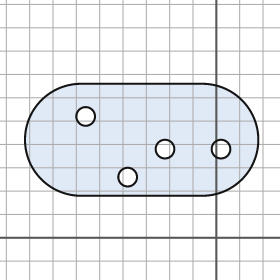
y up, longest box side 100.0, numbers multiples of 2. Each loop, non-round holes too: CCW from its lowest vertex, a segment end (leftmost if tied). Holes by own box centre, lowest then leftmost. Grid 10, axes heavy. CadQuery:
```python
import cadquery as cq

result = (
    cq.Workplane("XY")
    .moveTo(-58.0, 18.0)
    .lineTo(-6.0, 18.0)
    .threePointArc((18.0, 42.0), (-6.0, 66.0))
    .lineTo(-58.0, 66.0)
    .threePointArc((-82.0, 42.0), (-58.0, 18.0))
    .close()
    .moveTo(-38.0, 26.0)
    .circle(4.0)
    .moveTo(-22.0, 38.0)
    .circle(4.0)
    .moveTo(2.0, 38.0)
    .circle(4.0)
    .moveTo(-56.0, 52.0)
    .circle(4.0)
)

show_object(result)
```